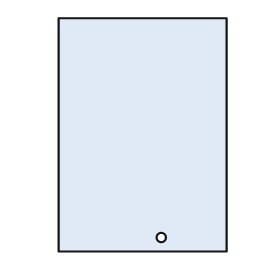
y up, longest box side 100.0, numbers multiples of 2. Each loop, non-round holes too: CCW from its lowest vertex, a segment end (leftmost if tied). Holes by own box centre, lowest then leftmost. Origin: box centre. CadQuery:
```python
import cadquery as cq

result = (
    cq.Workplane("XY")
    .moveTo(-36.0, -50.0)
    .lineTo(36.0, -50.0)
    .lineTo(36.0, 50.0)
    .lineTo(-36.0, 50.0)
    .close()
    .moveTo(8.0, -44.0)
    .circle(2.0)
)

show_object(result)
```